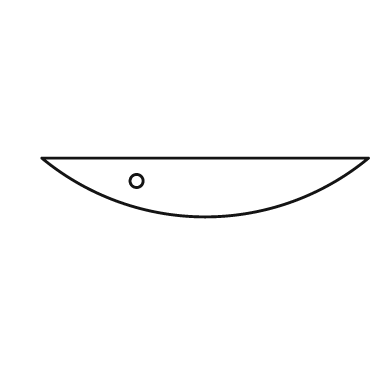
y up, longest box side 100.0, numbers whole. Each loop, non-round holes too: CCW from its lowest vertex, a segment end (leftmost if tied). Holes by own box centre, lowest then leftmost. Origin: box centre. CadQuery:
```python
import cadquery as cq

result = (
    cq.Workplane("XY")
    .moveTo(-50.0, 9.0)
    .threePointArc((0.0, -9.0), (50.0, 9.0))
    .close()
    .moveTo(-21.0, 2.0)
    .circle(2.0)
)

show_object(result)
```